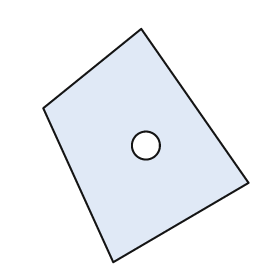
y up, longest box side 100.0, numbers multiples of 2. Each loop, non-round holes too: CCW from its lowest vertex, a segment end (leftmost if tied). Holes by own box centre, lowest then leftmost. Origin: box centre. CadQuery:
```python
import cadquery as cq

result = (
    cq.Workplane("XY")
    .moveTo(-14.0, -50.0)
    .lineTo(44.0, -16.0)
    .lineTo(-2.0, 50.0)
    .lineTo(-44.0, 16.0)
    .close()
    .moveTo(0.0, 0.0)
    .circle(6.0)
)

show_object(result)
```